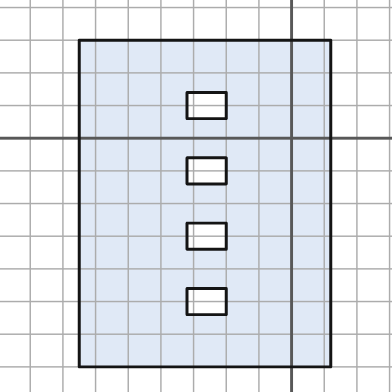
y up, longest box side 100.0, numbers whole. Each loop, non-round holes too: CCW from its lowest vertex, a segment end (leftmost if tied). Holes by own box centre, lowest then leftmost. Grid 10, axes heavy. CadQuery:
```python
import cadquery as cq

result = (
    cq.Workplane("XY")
    .moveTo(-65.0, -70.0)
    .lineTo(12.0, -70.0)
    .lineTo(12.0, 30.0)
    .lineTo(-65.0, 30.0)
    .close()
    .moveTo(-32.0, -54.0)
    .lineTo(-20.0, -54.0)
    .lineTo(-20.0, -46.0)
    .lineTo(-32.0, -46.0)
    .close()
    .moveTo(-32.0, -34.0)
    .lineTo(-20.0, -34.0)
    .lineTo(-20.0, -26.0)
    .lineTo(-32.0, -26.0)
    .close()
    .moveTo(-32.0, -14.0)
    .lineTo(-20.0, -14.0)
    .lineTo(-20.0, -6.0)
    .lineTo(-32.0, -6.0)
    .close()
    .moveTo(-32.0, 6.0)
    .lineTo(-20.0, 6.0)
    .lineTo(-20.0, 14.0)
    .lineTo(-32.0, 14.0)
    .close()
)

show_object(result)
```